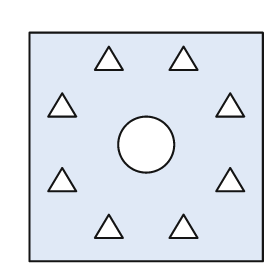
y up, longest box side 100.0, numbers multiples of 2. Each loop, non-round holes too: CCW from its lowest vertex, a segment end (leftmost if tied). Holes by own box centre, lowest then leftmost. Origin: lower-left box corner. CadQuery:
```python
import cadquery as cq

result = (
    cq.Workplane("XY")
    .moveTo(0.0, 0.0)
    .lineTo(100.0, 0.0)
    .lineTo(100.0, 98.0)
    .lineTo(0.0, 98.0)
    .close()
    .moveTo(28.0, 10.0)
    .lineTo(40.0, 10.0)
    .lineTo(34.0, 20.0)
    .close()
    .moveTo(60.0, 10.0)
    .lineTo(72.0, 10.0)
    .lineTo(66.0, 20.0)
    .close()
    .moveTo(8.0, 30.0)
    .lineTo(20.0, 30.0)
    .lineTo(14.0, 40.0)
    .close()
    .moveTo(80.0, 30.0)
    .lineTo(92.0, 30.0)
    .lineTo(86.0, 40.0)
    .close()
    .moveTo(50.0, 50.0)
    .circle(12.0)
    .moveTo(8.0, 62.0)
    .lineTo(20.0, 62.0)
    .lineTo(14.0, 72.0)
    .close()
    .moveTo(80.0, 62.0)
    .lineTo(92.0, 62.0)
    .lineTo(86.0, 72.0)
    .close()
    .moveTo(28.0, 82.0)
    .lineTo(40.0, 82.0)
    .lineTo(34.0, 92.0)
    .close()
    .moveTo(60.0, 82.0)
    .lineTo(72.0, 82.0)
    .lineTo(66.0, 92.0)
    .close()
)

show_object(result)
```